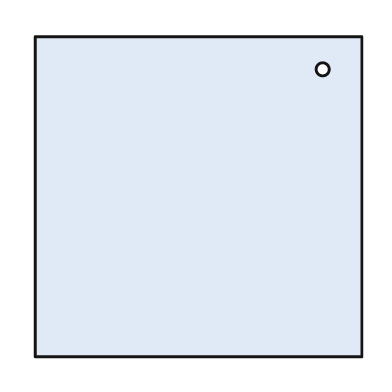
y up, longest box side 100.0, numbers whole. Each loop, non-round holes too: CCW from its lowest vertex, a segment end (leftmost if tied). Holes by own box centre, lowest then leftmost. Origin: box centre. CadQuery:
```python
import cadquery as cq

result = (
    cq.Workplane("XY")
    .moveTo(-50.0, -49.0)
    .lineTo(50.0, -49.0)
    .lineTo(50.0, 49.0)
    .lineTo(-50.0, 49.0)
    .close()
    .moveTo(38.0, 39.0)
    .circle(2.0)
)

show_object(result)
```